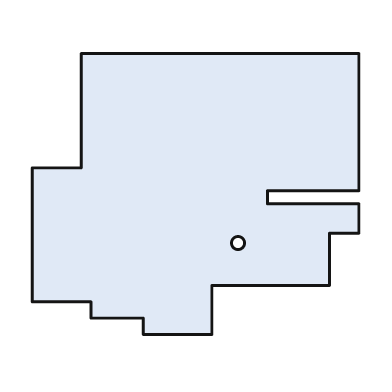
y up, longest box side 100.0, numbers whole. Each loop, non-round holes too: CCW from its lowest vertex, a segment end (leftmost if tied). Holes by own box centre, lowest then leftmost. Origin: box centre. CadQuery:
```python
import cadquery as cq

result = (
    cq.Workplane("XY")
    .moveTo(-16.0, -43.0)
    .lineTo(5.0, -43.0)
    .lineTo(5.0, -28.0)
    .lineTo(41.0, -28.0)
    .lineTo(41.0, -12.0)
    .lineTo(50.0, -12.0)
    .lineTo(50.0, -3.0)
    .lineTo(22.0, -3.0)
    .lineTo(22.0, 1.0)
    .lineTo(50.0, 1.0)
    .lineTo(50.0, 43.0)
    .lineTo(-35.0, 43.0)
    .lineTo(-35.0, 8.0)
    .lineTo(-50.0, 8.0)
    .lineTo(-50.0, -33.0)
    .lineTo(-32.0, -33.0)
    .lineTo(-32.0, -38.0)
    .lineTo(-16.0, -38.0)
    .close()
    .moveTo(13.0, -15.0)
    .circle(2.0)
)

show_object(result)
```